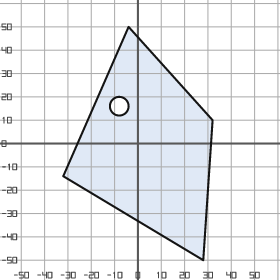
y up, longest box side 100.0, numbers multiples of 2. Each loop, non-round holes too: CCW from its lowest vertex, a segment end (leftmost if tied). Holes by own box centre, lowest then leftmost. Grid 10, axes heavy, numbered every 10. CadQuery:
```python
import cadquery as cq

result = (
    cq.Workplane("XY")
    .moveTo(28.0, -50.0)
    .lineTo(32.0, 10.0)
    .lineTo(-4.0, 50.0)
    .lineTo(-32.0, -14.0)
    .close()
    .moveTo(-8.0, 16.0)
    .circle(4.0)
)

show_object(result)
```